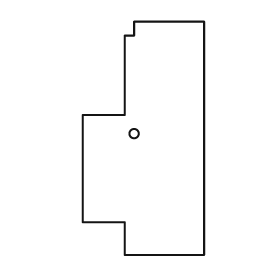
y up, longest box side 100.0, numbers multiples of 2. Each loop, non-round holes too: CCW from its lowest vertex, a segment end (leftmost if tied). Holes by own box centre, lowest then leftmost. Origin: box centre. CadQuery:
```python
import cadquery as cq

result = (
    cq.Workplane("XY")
    .moveTo(-8.0, -50.0)
    .lineTo(26.0, -50.0)
    .lineTo(26.0, 50.0)
    .lineTo(-4.0, 50.0)
    .lineTo(-4.0, 44.0)
    .lineTo(-8.0, 44.0)
    .lineTo(-8.0, 10.0)
    .lineTo(-26.0, 10.0)
    .lineTo(-26.0, -36.0)
    .lineTo(-8.0, -36.0)
    .close()
    .moveTo(-4.0, 2.0)
    .circle(2.0)
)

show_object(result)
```